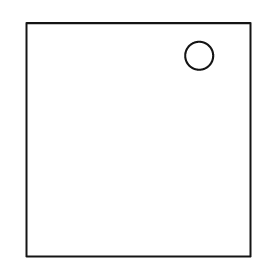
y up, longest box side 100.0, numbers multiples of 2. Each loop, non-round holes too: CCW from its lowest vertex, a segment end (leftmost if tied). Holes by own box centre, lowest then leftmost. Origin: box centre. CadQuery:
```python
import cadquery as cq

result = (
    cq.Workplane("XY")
    .moveTo(-48.0, -50.0)
    .lineTo(48.0, -50.0)
    .lineTo(48.0, 50.0)
    .lineTo(-48.0, 50.0)
    .close()
    .moveTo(26.0, 36.0)
    .circle(6.0)
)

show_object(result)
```